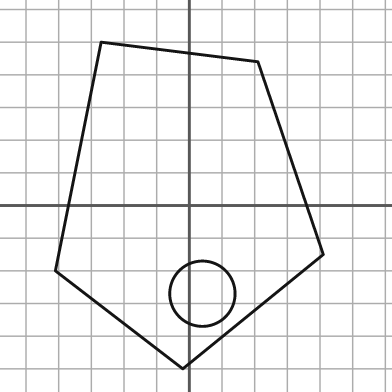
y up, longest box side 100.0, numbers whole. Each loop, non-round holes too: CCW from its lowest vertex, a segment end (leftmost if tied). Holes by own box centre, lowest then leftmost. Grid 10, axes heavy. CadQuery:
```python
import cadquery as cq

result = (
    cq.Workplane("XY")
    .moveTo(-2.0, -50.0)
    .lineTo(41.0, -15.0)
    .lineTo(21.0, 44.0)
    .lineTo(-27.0, 50.0)
    .lineTo(-41.0, -20.0)
    .close()
    .moveTo(4.0, -27.0)
    .circle(10.0)
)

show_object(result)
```